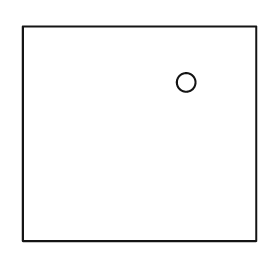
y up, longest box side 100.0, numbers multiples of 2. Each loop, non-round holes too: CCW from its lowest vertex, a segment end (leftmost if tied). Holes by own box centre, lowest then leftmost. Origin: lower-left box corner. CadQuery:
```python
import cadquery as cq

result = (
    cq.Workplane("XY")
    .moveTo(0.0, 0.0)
    .lineTo(100.0, 0.0)
    .lineTo(100.0, 92.0)
    .lineTo(0.0, 92.0)
    .close()
    .moveTo(70.0, 68.0)
    .circle(4.0)
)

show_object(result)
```